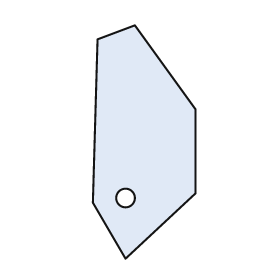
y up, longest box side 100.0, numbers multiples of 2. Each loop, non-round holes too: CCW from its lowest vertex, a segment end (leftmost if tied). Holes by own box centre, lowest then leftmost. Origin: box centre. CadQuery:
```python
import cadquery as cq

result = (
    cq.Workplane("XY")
    .moveTo(-8.0, -50.0)
    .lineTo(22.0, -22.0)
    .lineTo(22.0, 14.0)
    .lineTo(-4.0, 50.0)
    .lineTo(-20.0, 44.0)
    .lineTo(-22.0, -26.0)
    .close()
    .moveTo(-8.0, -24.0)
    .circle(4.0)
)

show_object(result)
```